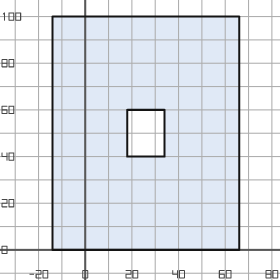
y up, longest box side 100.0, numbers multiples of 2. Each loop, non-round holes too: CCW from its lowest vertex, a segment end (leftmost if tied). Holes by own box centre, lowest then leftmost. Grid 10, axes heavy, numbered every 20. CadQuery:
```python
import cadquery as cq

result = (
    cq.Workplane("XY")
    .moveTo(-14.0, 0.0)
    .lineTo(66.0, 0.0)
    .lineTo(66.0, 100.0)
    .lineTo(-14.0, 100.0)
    .close()
    .moveTo(18.0, 40.0)
    .lineTo(34.0, 40.0)
    .lineTo(34.0, 60.0)
    .lineTo(18.0, 60.0)
    .close()
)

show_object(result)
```